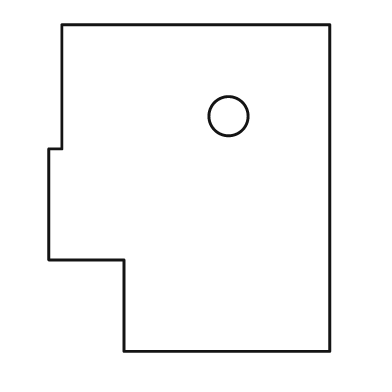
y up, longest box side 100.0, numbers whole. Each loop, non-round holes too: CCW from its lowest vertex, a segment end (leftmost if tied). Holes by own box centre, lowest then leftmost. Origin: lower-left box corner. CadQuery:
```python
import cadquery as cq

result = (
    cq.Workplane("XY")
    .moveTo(23.0, 0.0)
    .lineTo(86.0, 0.0)
    .lineTo(86.0, 100.0)
    .lineTo(4.0, 100.0)
    .lineTo(4.0, 62.0)
    .lineTo(0.0, 62.0)
    .lineTo(0.0, 28.0)
    .lineTo(23.0, 28.0)
    .close()
    .moveTo(55.0, 72.0)
    .circle(6.0)
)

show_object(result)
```